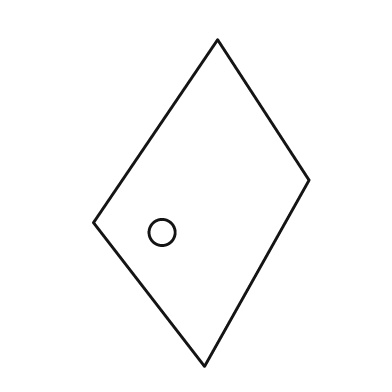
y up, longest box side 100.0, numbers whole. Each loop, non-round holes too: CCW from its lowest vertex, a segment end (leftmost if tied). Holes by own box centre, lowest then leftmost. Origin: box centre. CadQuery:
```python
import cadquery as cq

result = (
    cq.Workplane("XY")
    .moveTo(1.0, -50.0)
    .lineTo(33.0, 7.0)
    .lineTo(5.0, 50.0)
    .lineTo(-33.0, -6.0)
    .close()
    .moveTo(-12.0, -9.0)
    .circle(4.0)
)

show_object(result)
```